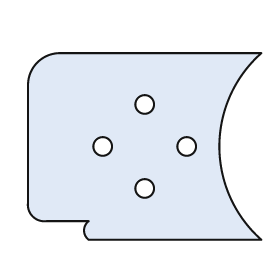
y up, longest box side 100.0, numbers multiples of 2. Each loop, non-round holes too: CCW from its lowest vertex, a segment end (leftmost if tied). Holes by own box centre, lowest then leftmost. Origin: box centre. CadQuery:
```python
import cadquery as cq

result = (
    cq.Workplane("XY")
    .moveTo(-24.0, -40.0)
    .lineTo(50.0, -40.0)
    .threePointArc((32.0, 0.0), (50.0, 40.0))
    .lineTo(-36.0, 40.0)
    .threePointArc((-46.0, 36.0), (-50.0, 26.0))
    .lineTo(-50.0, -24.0)
    .threePointArc((-48.0, -30.0), (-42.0, -32.0))
    .lineTo(-24.0, -32.0)
    .threePointArc((-26.0, -36.0), (-24.0, -40.0))
    .close()
    .moveTo(0.0, -18.0)
    .circle(4.0)
    .moveTo(-18.0, 0.0)
    .circle(4.0)
    .moveTo(18.0, 0.0)
    .circle(4.0)
    .moveTo(0.0, 18.0)
    .circle(4.0)
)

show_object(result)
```